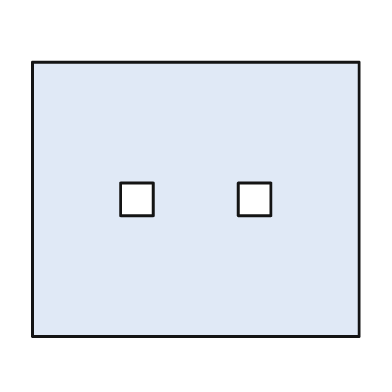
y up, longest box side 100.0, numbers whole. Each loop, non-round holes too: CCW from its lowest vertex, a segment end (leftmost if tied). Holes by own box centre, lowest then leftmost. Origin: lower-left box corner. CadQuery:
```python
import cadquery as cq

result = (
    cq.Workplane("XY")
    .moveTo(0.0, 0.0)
    .lineTo(100.0, 0.0)
    .lineTo(100.0, 84.0)
    .lineTo(0.0, 84.0)
    .close()
    .moveTo(27.0, 37.0)
    .lineTo(37.0, 37.0)
    .lineTo(37.0, 47.0)
    .lineTo(27.0, 47.0)
    .close()
    .moveTo(63.0, 37.0)
    .lineTo(73.0, 37.0)
    .lineTo(73.0, 47.0)
    .lineTo(63.0, 47.0)
    .close()
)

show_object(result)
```